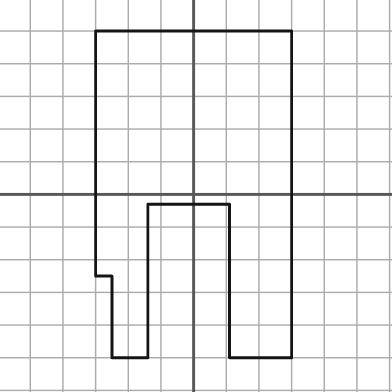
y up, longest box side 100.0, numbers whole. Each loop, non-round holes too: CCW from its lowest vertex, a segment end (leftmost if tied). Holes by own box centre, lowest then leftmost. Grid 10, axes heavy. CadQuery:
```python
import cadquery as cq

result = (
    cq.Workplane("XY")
    .moveTo(-25.0, -50.0)
    .lineTo(-14.0, -50.0)
    .lineTo(-14.0, -3.0)
    .lineTo(11.0, -3.0)
    .lineTo(11.0, -50.0)
    .lineTo(30.0, -50.0)
    .lineTo(30.0, 50.0)
    .lineTo(-30.0, 50.0)
    .lineTo(-30.0, -25.0)
    .lineTo(-25.0, -25.0)
    .close()
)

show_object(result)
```